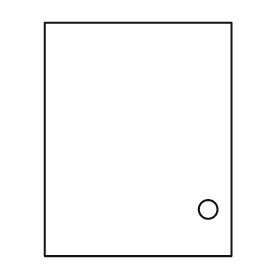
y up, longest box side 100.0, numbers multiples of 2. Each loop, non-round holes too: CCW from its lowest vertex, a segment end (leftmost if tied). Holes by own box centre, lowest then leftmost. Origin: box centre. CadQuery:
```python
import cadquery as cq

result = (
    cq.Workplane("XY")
    .moveTo(-40.0, -50.0)
    .lineTo(40.0, -50.0)
    .lineTo(40.0, 50.0)
    .lineTo(-40.0, 50.0)
    .close()
    .moveTo(30.0, -30.0)
    .circle(4.0)
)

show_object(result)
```